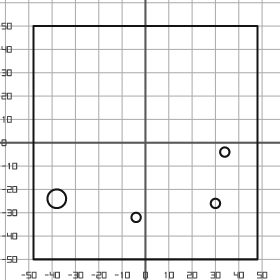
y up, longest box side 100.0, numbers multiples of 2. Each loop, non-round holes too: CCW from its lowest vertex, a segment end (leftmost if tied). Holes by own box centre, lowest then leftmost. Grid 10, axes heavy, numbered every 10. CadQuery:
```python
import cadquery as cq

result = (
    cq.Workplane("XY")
    .moveTo(-48.0, -50.0)
    .lineTo(48.0, -50.0)
    .lineTo(48.0, 50.0)
    .lineTo(-48.0, 50.0)
    .close()
    .moveTo(-4.0, -32.0)
    .circle(2.0)
    .moveTo(30.0, -26.0)
    .circle(2.0)
    .moveTo(-38.0, -24.0)
    .circle(4.0)
    .moveTo(34.0, -4.0)
    .circle(2.0)
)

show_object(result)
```